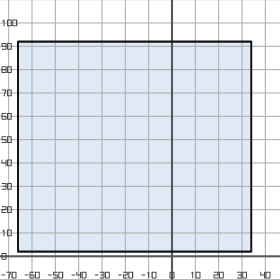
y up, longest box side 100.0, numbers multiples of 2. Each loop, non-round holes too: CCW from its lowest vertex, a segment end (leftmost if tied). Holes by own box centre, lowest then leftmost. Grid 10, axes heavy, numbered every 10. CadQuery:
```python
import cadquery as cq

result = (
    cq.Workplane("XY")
    .moveTo(-66.0, 2.0)
    .lineTo(34.0, 2.0)
    .lineTo(34.0, 92.0)
    .lineTo(-66.0, 92.0)
    .close()
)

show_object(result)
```